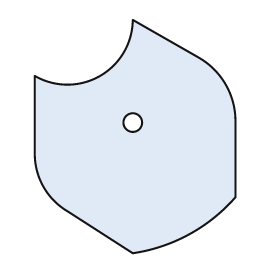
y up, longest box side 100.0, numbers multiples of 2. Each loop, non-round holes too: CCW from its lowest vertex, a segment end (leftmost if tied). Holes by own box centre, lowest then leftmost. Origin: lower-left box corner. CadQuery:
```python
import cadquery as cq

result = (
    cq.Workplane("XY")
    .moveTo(42.0, 0.0)
    .threePointArc((66.0, 8.0), (86.0, 24.0))
    .lineTo(86.0, 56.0)
    .threePointArc((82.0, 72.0), (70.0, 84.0))
    .lineTo(42.0, 100.0)
    .threePointArc((28.0, 76.0), (0.0, 76.0))
    .lineTo(0.0, 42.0)
    .threePointArc((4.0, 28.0), (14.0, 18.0))
    .close()
    .moveTo(42.0, 56.0)
    .circle(4.0)
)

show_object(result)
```